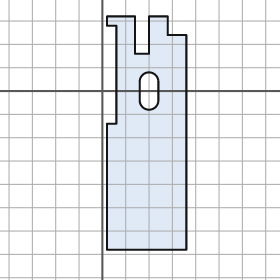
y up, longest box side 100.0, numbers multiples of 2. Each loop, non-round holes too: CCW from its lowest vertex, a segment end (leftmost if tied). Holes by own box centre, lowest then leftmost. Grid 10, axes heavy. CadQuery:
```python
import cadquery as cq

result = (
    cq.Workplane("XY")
    .moveTo(2.0, -68.0)
    .lineTo(36.0, -68.0)
    .lineTo(36.0, 24.0)
    .lineTo(28.0, 24.0)
    .lineTo(28.0, 32.0)
    .lineTo(20.0, 32.0)
    .lineTo(20.0, 16.0)
    .lineTo(14.0, 16.0)
    .lineTo(14.0, 32.0)
    .lineTo(2.0, 32.0)
    .lineTo(2.0, 28.0)
    .lineTo(6.0, 28.0)
    .lineTo(6.0, -14.0)
    .lineTo(2.0, -14.0)
    .close()
    .moveTo(16.0, -4.0)
    .threePointArc((20.0, -8.0), (24.0, -4.0))
    .lineTo(24.0, 4.0)
    .threePointArc((20.0, 8.0), (16.0, 4.0))
    .close()
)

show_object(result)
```